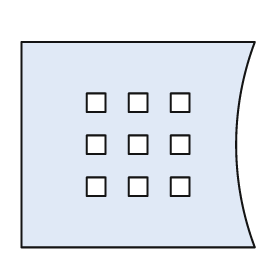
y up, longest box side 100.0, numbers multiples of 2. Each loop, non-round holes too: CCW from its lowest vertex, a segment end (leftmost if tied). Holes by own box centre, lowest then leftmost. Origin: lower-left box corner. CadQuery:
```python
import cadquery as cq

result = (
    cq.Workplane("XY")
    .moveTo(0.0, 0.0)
    .lineTo(100.0, 0.0)
    .threePointArc((92.0, 44.0), (100.0, 88.0))
    .lineTo(0.0, 88.0)
    .close()
    .moveTo(28.0, 22.0)
    .lineTo(36.0, 22.0)
    .lineTo(36.0, 30.0)
    .lineTo(28.0, 30.0)
    .close()
    .moveTo(46.0, 22.0)
    .lineTo(54.0, 22.0)
    .lineTo(54.0, 30.0)
    .lineTo(46.0, 30.0)
    .close()
    .moveTo(64.0, 22.0)
    .lineTo(72.0, 22.0)
    .lineTo(72.0, 30.0)
    .lineTo(64.0, 30.0)
    .close()
    .moveTo(28.0, 40.0)
    .lineTo(36.0, 40.0)
    .lineTo(36.0, 48.0)
    .lineTo(28.0, 48.0)
    .close()
    .moveTo(46.0, 40.0)
    .lineTo(54.0, 40.0)
    .lineTo(54.0, 48.0)
    .lineTo(46.0, 48.0)
    .close()
    .moveTo(64.0, 40.0)
    .lineTo(72.0, 40.0)
    .lineTo(72.0, 48.0)
    .lineTo(64.0, 48.0)
    .close()
    .moveTo(28.0, 58.0)
    .lineTo(36.0, 58.0)
    .lineTo(36.0, 66.0)
    .lineTo(28.0, 66.0)
    .close()
    .moveTo(46.0, 58.0)
    .lineTo(54.0, 58.0)
    .lineTo(54.0, 66.0)
    .lineTo(46.0, 66.0)
    .close()
    .moveTo(64.0, 58.0)
    .lineTo(72.0, 58.0)
    .lineTo(72.0, 66.0)
    .lineTo(64.0, 66.0)
    .close()
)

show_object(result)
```